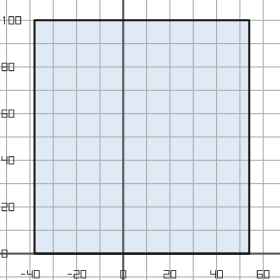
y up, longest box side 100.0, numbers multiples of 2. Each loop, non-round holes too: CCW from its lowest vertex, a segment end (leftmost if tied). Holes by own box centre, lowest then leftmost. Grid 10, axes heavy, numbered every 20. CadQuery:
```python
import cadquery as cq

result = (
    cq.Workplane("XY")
    .moveTo(-38.0, 0.0)
    .lineTo(54.0, 0.0)
    .lineTo(54.0, 100.0)
    .lineTo(-38.0, 100.0)
    .close()
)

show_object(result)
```